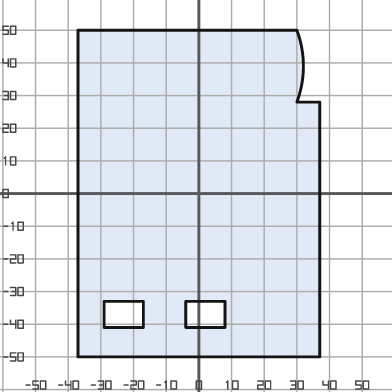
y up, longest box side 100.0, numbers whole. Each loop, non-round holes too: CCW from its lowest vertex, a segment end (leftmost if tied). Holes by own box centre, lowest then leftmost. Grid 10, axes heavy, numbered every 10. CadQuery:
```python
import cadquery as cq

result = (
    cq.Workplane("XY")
    .moveTo(-37.0, -50.0)
    .lineTo(37.0, -50.0)
    .lineTo(37.0, 28.0)
    .lineTo(30.0, 28.0)
    .threePointArc((32.0, 39.0), (30.0, 50.0))
    .lineTo(-37.0, 50.0)
    .close()
    .moveTo(-29.0, -41.0)
    .lineTo(-17.0, -41.0)
    .lineTo(-17.0, -33.0)
    .lineTo(-29.0, -33.0)
    .close()
    .moveTo(-4.0, -41.0)
    .lineTo(8.0, -41.0)
    .lineTo(8.0, -33.0)
    .lineTo(-4.0, -33.0)
    .close()
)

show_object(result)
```